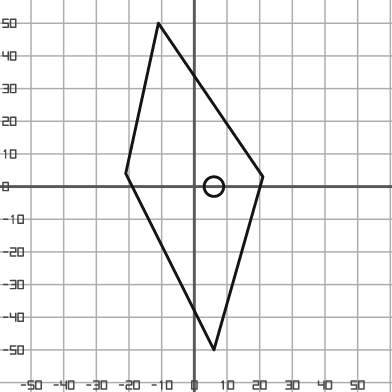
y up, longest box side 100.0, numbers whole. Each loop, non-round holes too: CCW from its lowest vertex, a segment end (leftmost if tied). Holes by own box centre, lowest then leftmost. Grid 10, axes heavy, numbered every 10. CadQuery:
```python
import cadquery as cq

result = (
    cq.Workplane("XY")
    .moveTo(6.0, -50.0)
    .lineTo(21.0, 3.0)
    .lineTo(-11.0, 50.0)
    .lineTo(-21.0, 4.0)
    .close()
    .moveTo(6.0, 0.0)
    .circle(3.0)
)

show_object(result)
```